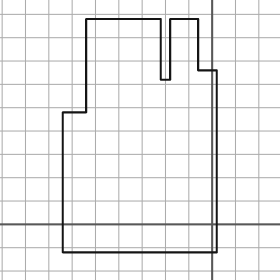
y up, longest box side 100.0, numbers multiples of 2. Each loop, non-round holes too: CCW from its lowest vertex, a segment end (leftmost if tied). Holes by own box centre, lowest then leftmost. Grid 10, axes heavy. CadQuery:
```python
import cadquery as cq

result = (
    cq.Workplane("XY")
    .moveTo(-64.0, -12.0)
    .lineTo(2.0, -12.0)
    .lineTo(2.0, 66.0)
    .lineTo(-6.0, 66.0)
    .lineTo(-6.0, 88.0)
    .lineTo(-18.0, 88.0)
    .lineTo(-18.0, 62.0)
    .lineTo(-22.0, 62.0)
    .lineTo(-22.0, 88.0)
    .lineTo(-54.0, 88.0)
    .lineTo(-54.0, 48.0)
    .lineTo(-64.0, 48.0)
    .close()
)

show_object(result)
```